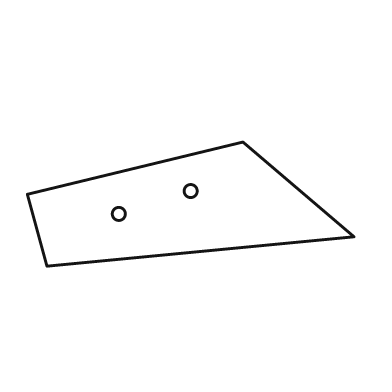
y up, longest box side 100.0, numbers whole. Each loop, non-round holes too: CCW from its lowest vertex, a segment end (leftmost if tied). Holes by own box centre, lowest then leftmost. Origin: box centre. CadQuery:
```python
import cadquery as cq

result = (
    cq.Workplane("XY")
    .moveTo(-44.0, -19.0)
    .lineTo(50.0, -10.0)
    .lineTo(16.0, 19.0)
    .lineTo(-50.0, 3.0)
    .close()
    .moveTo(-22.0, -3.0)
    .circle(2.0)
    .moveTo(0.0, 4.0)
    .circle(2.0)
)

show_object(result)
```